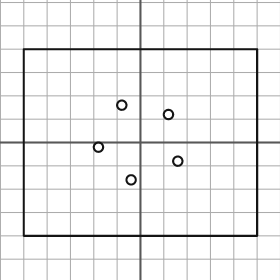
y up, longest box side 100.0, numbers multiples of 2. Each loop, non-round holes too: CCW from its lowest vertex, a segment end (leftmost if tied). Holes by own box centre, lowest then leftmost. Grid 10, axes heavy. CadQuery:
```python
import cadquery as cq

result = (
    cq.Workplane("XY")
    .moveTo(-50.0, -40.0)
    .lineTo(50.0, -40.0)
    .lineTo(50.0, 40.0)
    .lineTo(-50.0, 40.0)
    .close()
    .moveTo(-4.0, -16.0)
    .circle(2.0)
    .moveTo(16.0, -8.0)
    .circle(2.0)
    .moveTo(-18.0, -2.0)
    .circle(2.0)
    .moveTo(12.0, 12.0)
    .circle(2.0)
    .moveTo(-8.0, 16.0)
    .circle(2.0)
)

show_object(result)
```